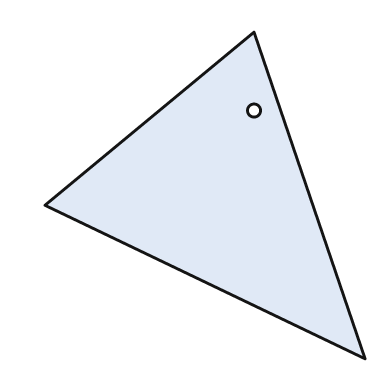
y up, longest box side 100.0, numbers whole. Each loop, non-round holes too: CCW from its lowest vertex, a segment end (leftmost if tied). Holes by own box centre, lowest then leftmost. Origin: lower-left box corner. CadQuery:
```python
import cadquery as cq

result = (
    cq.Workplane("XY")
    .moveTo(98.0, 0.0)
    .lineTo(64.0, 100.0)
    .lineTo(0.0, 47.0)
    .close()
    .moveTo(64.0, 76.0)
    .circle(2.0)
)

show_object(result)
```